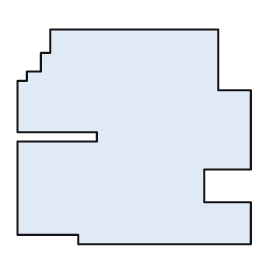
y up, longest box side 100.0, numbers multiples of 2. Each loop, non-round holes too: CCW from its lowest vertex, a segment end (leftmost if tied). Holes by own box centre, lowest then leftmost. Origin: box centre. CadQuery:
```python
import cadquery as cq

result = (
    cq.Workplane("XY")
    .moveTo(-24.0, -46.0)
    .lineTo(50.0, -46.0)
    .lineTo(50.0, -28.0)
    .lineTo(30.0, -28.0)
    .lineTo(30.0, -14.0)
    .lineTo(50.0, -14.0)
    .lineTo(50.0, 20.0)
    .lineTo(36.0, 20.0)
    .lineTo(36.0, 46.0)
    .lineTo(-36.0, 46.0)
    .lineTo(-36.0, 36.0)
    .lineTo(-40.0, 36.0)
    .lineTo(-40.0, 28.0)
    .lineTo(-46.0, 28.0)
    .lineTo(-46.0, 24.0)
    .lineTo(-50.0, 24.0)
    .lineTo(-50.0, 2.0)
    .lineTo(-16.0, 2.0)
    .lineTo(-16.0, -2.0)
    .lineTo(-50.0, -2.0)
    .lineTo(-50.0, -42.0)
    .lineTo(-24.0, -42.0)
    .close()
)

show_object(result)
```